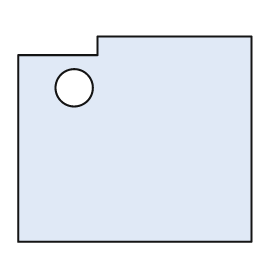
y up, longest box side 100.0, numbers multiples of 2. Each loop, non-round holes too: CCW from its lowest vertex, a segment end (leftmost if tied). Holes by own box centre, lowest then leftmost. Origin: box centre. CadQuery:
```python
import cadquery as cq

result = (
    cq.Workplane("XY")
    .moveTo(-50.0, -44.0)
    .lineTo(50.0, -44.0)
    .lineTo(50.0, 44.0)
    .lineTo(-16.0, 44.0)
    .lineTo(-16.0, 36.0)
    .lineTo(-50.0, 36.0)
    .close()
    .moveTo(-26.0, 22.0)
    .circle(8.0)
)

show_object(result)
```